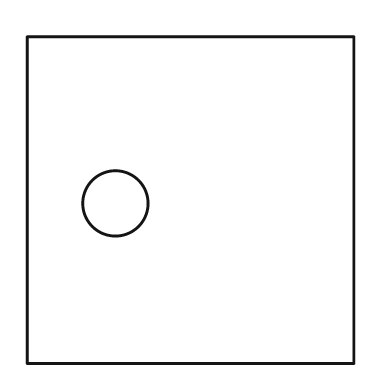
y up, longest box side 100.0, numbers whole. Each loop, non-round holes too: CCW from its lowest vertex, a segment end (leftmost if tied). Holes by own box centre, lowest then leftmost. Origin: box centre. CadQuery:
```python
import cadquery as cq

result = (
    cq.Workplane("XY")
    .moveTo(-50.0, -50.0)
    .lineTo(50.0, -50.0)
    .lineTo(50.0, 50.0)
    .lineTo(-50.0, 50.0)
    .close()
    .moveTo(-23.0, -1.0)
    .circle(10.0)
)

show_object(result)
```